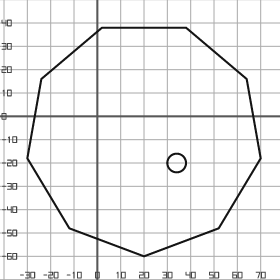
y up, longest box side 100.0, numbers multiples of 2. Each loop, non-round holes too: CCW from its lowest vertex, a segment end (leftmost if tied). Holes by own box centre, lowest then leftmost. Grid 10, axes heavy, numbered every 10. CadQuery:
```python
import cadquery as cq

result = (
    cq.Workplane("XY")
    .moveTo(20.0, -60.0)
    .lineTo(52.0, -48.0)
    .lineTo(70.0, -18.0)
    .lineTo(64.0, 16.0)
    .lineTo(38.0, 38.0)
    .lineTo(2.0, 38.0)
    .lineTo(-24.0, 16.0)
    .lineTo(-30.0, -18.0)
    .lineTo(-12.0, -48.0)
    .close()
    .moveTo(34.0, -20.0)
    .circle(4.0)
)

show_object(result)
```